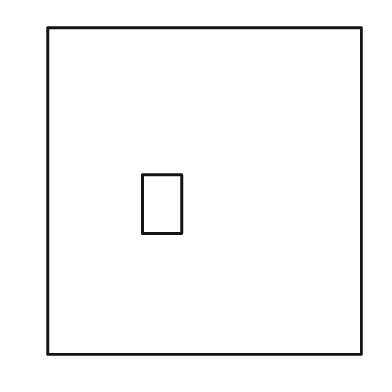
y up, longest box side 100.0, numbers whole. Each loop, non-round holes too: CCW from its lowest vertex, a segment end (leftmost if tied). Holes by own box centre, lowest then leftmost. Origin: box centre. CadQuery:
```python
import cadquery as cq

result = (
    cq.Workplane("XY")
    .moveTo(-48.0, -50.0)
    .lineTo(48.0, -50.0)
    .lineTo(48.0, 50.0)
    .lineTo(-48.0, 50.0)
    .close()
    .moveTo(-19.0, -13.0)
    .lineTo(-7.0, -13.0)
    .lineTo(-7.0, 5.0)
    .lineTo(-19.0, 5.0)
    .close()
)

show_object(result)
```